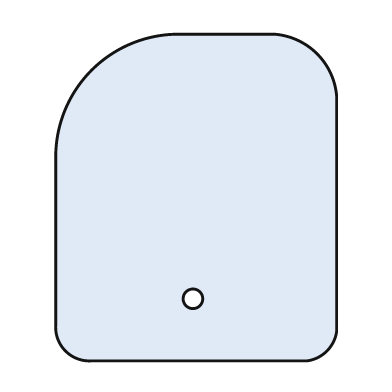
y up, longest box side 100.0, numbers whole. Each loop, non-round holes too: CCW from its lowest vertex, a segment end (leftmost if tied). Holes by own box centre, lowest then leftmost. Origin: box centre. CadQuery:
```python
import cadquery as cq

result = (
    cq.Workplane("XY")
    .moveTo(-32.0, -50.0)
    .lineTo(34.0, -50.0)
    .threePointArc((40.0, -47.0), (43.0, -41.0))
    .lineTo(43.0, 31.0)
    .threePointArc((37.0, 44.0), (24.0, 50.0))
    .lineTo(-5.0, 50.0)
    .threePointArc((-32.0, 39.0), (-43.0, 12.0))
    .lineTo(-43.0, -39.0)
    .threePointArc((-40.0, -47.0), (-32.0, -50.0))
    .close()
    .moveTo(-1.0, -31.0)
    .circle(3.0)
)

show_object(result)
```